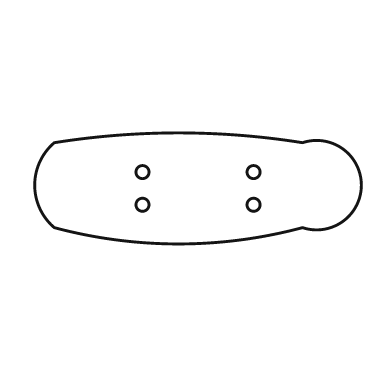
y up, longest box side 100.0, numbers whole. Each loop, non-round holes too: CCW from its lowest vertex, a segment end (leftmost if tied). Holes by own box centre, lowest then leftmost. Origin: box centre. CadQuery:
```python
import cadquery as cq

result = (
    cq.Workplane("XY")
    .moveTo(-44.0, -12.0)
    .threePointArc((-6.0, -17.0), (32.0, -12.0))
    .threePointArc((50.0, 1.0), (32.0, 14.0))
    .threePointArc((-6.0, 17.0), (-44.0, 14.0))
    .threePointArc((-50.0, 1.0), (-44.0, -12.0))
    .close()
    .moveTo(-17.0, -5.0)
    .circle(2.0)
    .moveTo(17.0, -5.0)
    .circle(2.0)
    .moveTo(-17.0, 5.0)
    .circle(2.0)
    .moveTo(17.0, 5.0)
    .circle(2.0)
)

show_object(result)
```